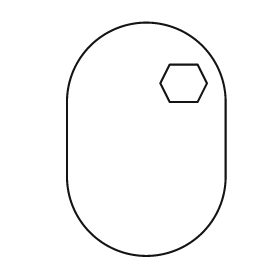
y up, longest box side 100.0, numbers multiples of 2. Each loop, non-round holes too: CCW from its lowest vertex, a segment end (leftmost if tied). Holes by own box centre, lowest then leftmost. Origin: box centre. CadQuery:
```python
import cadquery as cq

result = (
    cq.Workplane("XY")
    .moveTo(-34.0, -16.0)
    .threePointArc((0.0, -50.0), (34.0, -16.0))
    .lineTo(34.0, 16.0)
    .threePointArc((0.0, 50.0), (-34.0, 16.0))
    .close()
    .moveTo(10.0, 16.0)
    .lineTo(22.0, 16.0)
    .lineTo(26.0, 24.0)
    .lineTo(22.0, 32.0)
    .lineTo(10.0, 32.0)
    .lineTo(6.0, 24.0)
    .close()
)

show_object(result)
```